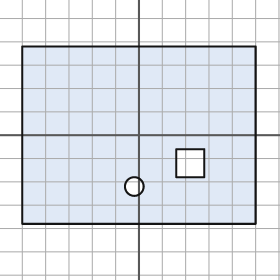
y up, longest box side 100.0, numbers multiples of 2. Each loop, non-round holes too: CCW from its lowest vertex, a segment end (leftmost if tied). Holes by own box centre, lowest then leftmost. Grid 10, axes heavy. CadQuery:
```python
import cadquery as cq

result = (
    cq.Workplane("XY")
    .moveTo(-50.0, -38.0)
    .lineTo(50.0, -38.0)
    .lineTo(50.0, 38.0)
    .lineTo(-50.0, 38.0)
    .close()
    .moveTo(-2.0, -22.0)
    .circle(4.0)
    .moveTo(16.0, -18.0)
    .lineTo(28.0, -18.0)
    .lineTo(28.0, -6.0)
    .lineTo(16.0, -6.0)
    .close()
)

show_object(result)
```